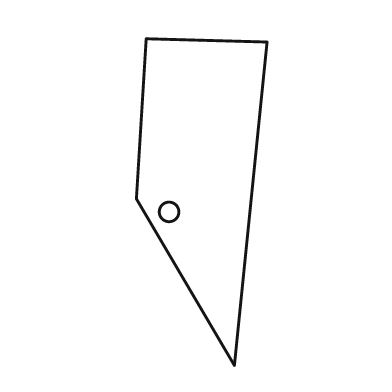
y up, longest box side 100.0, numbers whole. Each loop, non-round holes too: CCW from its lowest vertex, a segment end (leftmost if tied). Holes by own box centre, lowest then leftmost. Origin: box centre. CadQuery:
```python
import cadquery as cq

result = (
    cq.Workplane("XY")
    .moveTo(10.0, -50.0)
    .lineTo(20.0, 49.0)
    .lineTo(-17.0, 50.0)
    .lineTo(-20.0, 1.0)
    .close()
    .moveTo(-10.0, -3.0)
    .circle(3.0)
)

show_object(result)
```